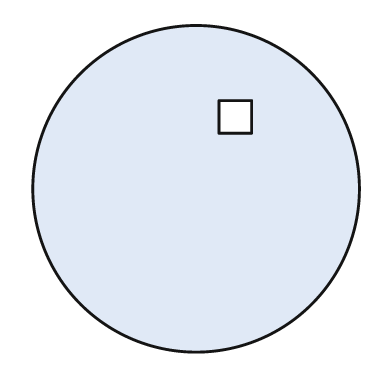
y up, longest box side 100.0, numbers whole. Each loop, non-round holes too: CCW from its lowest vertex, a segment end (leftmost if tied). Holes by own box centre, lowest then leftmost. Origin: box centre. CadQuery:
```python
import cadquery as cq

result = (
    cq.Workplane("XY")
    .moveTo(0.0, 0.0)
    .circle(50.0)
    .moveTo(7.0, 17.0)
    .lineTo(17.0, 17.0)
    .lineTo(17.0, 27.0)
    .lineTo(7.0, 27.0)
    .close()
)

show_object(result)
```